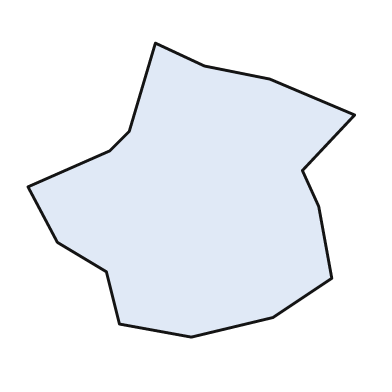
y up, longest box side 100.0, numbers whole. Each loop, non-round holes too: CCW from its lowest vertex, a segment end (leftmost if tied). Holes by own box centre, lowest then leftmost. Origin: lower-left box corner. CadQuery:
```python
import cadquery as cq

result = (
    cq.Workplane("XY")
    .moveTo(50.0, 0.0)
    .lineTo(75.0, 6.0)
    .lineTo(93.0, 18.0)
    .lineTo(89.0, 40.0)
    .lineTo(84.0, 51.0)
    .lineTo(100.0, 68.0)
    .lineTo(74.0, 79.0)
    .lineTo(54.0, 83.0)
    .lineTo(39.0, 90.0)
    .lineTo(31.0, 63.0)
    .lineTo(25.0, 57.0)
    .lineTo(0.0, 46.0)
    .lineTo(9.0, 29.0)
    .lineTo(24.0, 20.0)
    .lineTo(28.0, 4.0)
    .close()
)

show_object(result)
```